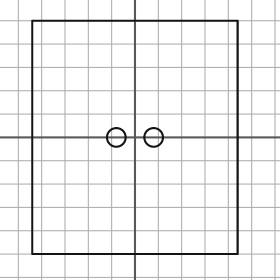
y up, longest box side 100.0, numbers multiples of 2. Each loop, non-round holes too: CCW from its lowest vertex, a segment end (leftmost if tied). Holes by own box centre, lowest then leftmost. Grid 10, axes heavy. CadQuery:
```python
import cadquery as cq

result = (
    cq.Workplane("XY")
    .moveTo(-44.0, -50.0)
    .lineTo(44.0, -50.0)
    .lineTo(44.0, 50.0)
    .lineTo(-44.0, 50.0)
    .close()
    .moveTo(-8.0, 0.0)
    .circle(4.0)
    .moveTo(8.0, 0.0)
    .circle(4.0)
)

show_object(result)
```